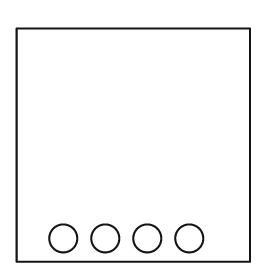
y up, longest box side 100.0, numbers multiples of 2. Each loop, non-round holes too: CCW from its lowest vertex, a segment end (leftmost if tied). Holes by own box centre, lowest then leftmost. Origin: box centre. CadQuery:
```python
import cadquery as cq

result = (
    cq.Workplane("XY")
    .moveTo(-50.0, -50.0)
    .lineTo(50.0, -50.0)
    .lineTo(50.0, 50.0)
    .lineTo(-50.0, 50.0)
    .close()
    .moveTo(-30.0, -40.0)
    .circle(6.0)
    .moveTo(-12.0, -40.0)
    .circle(6.0)
    .moveTo(6.0, -40.0)
    .circle(6.0)
    .moveTo(24.0, -40.0)
    .circle(6.0)
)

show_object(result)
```